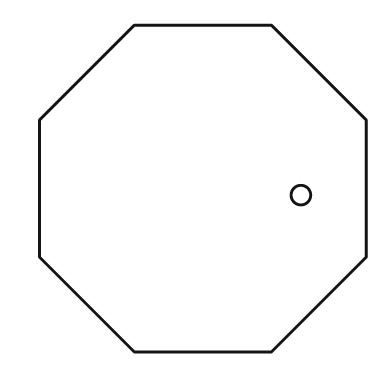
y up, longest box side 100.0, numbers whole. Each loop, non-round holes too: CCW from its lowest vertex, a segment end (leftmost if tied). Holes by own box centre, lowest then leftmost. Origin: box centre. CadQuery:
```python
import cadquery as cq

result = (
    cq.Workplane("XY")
    .moveTo(-21.0, -50.0)
    .lineTo(21.0, -50.0)
    .lineTo(50.0, -21.0)
    .lineTo(50.0, 21.0)
    .lineTo(21.0, 50.0)
    .lineTo(-21.0, 50.0)
    .lineTo(-50.0, 21.0)
    .lineTo(-50.0, -21.0)
    .close()
    .moveTo(30.0, -2.0)
    .circle(3.0)
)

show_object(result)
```